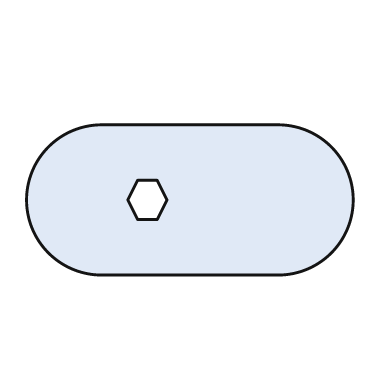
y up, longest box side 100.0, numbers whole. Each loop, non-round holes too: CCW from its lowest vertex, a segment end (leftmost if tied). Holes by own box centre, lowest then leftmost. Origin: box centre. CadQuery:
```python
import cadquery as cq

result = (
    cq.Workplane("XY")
    .moveTo(-27.0, -23.0)
    .lineTo(27.0, -23.0)
    .threePointArc((50.0, 0.0), (27.0, 23.0))
    .lineTo(-27.0, 23.0)
    .threePointArc((-50.0, 0.0), (-27.0, -23.0))
    .close()
    .moveTo(-16.0, -6.0)
    .lineTo(-10.0, -6.0)
    .lineTo(-7.0, 0.0)
    .lineTo(-10.0, 6.0)
    .lineTo(-16.0, 6.0)
    .lineTo(-19.0, 0.0)
    .close()
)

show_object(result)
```